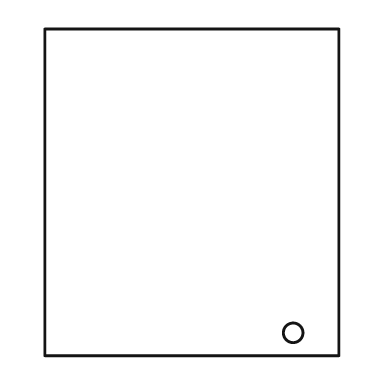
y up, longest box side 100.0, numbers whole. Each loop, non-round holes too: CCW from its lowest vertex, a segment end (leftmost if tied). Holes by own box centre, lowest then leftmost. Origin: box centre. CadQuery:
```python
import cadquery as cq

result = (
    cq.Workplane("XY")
    .moveTo(-45.0, -50.0)
    .lineTo(45.0, -50.0)
    .lineTo(45.0, 50.0)
    .lineTo(-45.0, 50.0)
    .close()
    .moveTo(31.0, -43.0)
    .circle(3.0)
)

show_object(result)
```